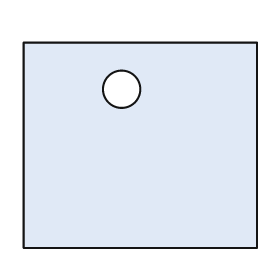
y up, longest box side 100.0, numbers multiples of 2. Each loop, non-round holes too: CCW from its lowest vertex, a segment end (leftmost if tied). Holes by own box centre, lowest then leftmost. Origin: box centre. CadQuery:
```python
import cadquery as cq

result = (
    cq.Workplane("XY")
    .moveTo(-50.0, -44.0)
    .lineTo(50.0, -44.0)
    .lineTo(50.0, 44.0)
    .lineTo(-50.0, 44.0)
    .close()
    .moveTo(-8.0, 24.0)
    .circle(8.0)
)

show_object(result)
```